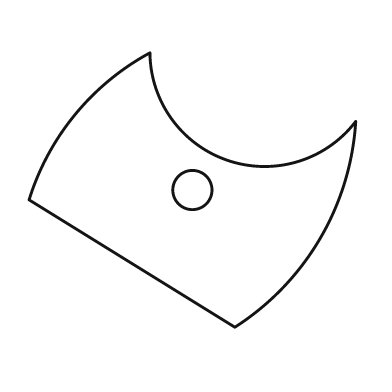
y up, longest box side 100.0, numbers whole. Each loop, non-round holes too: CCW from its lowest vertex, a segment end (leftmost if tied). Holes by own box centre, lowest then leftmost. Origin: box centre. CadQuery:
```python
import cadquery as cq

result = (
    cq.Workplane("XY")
    .moveTo(13.0, -42.0)
    .threePointArc((39.0, -15.0), (50.0, 21.0))
    .threePointArc((11.0, 9.0), (-13.0, 42.0))
    .threePointArc((-36.0, 23.0), (-50.0, -3.0))
    .close()
    .moveTo(0.0, 0.0)
    .circle(6.0)
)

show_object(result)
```